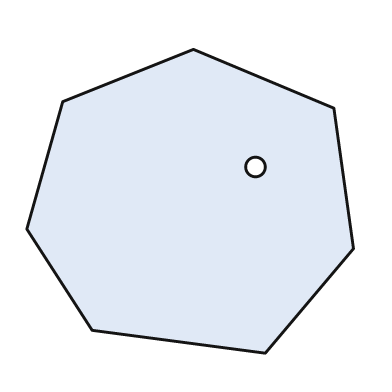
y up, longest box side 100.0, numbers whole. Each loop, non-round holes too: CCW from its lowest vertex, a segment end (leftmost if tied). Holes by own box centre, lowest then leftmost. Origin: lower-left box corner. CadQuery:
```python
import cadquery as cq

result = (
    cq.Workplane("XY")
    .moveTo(73.0, 0.0)
    .lineTo(100.0, 32.0)
    .lineTo(94.0, 75.0)
    .lineTo(51.0, 93.0)
    .lineTo(11.0, 77.0)
    .lineTo(0.0, 38.0)
    .lineTo(20.0, 7.0)
    .close()
    .moveTo(70.0, 57.0)
    .circle(3.0)
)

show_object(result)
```